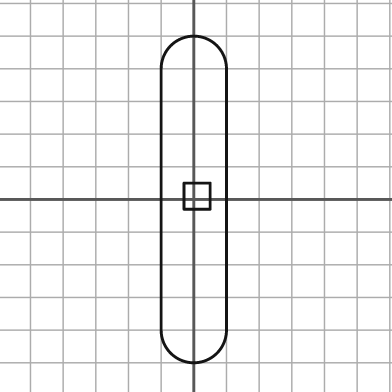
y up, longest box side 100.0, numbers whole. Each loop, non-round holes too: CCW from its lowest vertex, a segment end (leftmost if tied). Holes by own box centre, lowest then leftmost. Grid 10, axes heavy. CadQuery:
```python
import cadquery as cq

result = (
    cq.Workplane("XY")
    .moveTo(-10.0, -40.0)
    .threePointArc((0.0, -50.0), (10.0, -40.0))
    .lineTo(10.0, 40.0)
    .threePointArc((0.0, 50.0), (-10.0, 40.0))
    .close()
    .moveTo(-3.0, -3.0)
    .lineTo(5.0, -3.0)
    .lineTo(5.0, 5.0)
    .lineTo(-3.0, 5.0)
    .close()
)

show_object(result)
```